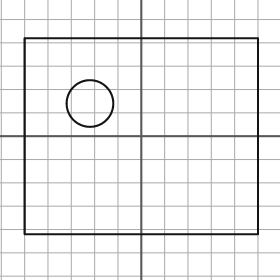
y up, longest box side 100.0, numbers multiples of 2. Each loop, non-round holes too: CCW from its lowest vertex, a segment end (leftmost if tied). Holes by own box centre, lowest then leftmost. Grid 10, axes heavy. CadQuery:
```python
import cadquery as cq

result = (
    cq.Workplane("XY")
    .moveTo(-50.0, -42.0)
    .lineTo(50.0, -42.0)
    .lineTo(50.0, 42.0)
    .lineTo(-50.0, 42.0)
    .close()
    .moveTo(-22.0, 14.0)
    .circle(10.0)
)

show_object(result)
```